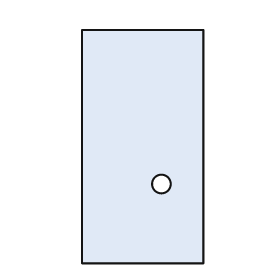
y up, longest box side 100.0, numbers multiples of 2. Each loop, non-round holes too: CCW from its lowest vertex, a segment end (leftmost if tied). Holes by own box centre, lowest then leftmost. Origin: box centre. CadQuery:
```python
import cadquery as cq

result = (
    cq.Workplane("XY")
    .moveTo(-26.0, -50.0)
    .lineTo(26.0, -50.0)
    .lineTo(26.0, 50.0)
    .lineTo(-26.0, 50.0)
    .close()
    .moveTo(8.0, -16.0)
    .circle(4.0)
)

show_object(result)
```